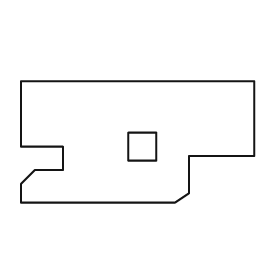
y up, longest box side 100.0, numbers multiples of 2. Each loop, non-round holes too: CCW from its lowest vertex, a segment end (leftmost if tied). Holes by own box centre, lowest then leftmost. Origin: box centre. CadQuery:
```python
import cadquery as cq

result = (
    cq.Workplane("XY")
    .moveTo(-50.0, -26.0)
    .lineTo(16.0, -26.0)
    .lineTo(22.0, -22.0)
    .lineTo(22.0, -6.0)
    .lineTo(50.0, -6.0)
    .lineTo(50.0, 26.0)
    .lineTo(-50.0, 26.0)
    .lineTo(-50.0, -2.0)
    .lineTo(-32.0, -2.0)
    .lineTo(-32.0, -12.0)
    .lineTo(-44.0, -12.0)
    .lineTo(-50.0, -18.0)
    .close()
    .moveTo(-4.0, -8.0)
    .lineTo(8.0, -8.0)
    .lineTo(8.0, 4.0)
    .lineTo(-4.0, 4.0)
    .close()
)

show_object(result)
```